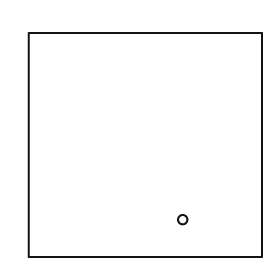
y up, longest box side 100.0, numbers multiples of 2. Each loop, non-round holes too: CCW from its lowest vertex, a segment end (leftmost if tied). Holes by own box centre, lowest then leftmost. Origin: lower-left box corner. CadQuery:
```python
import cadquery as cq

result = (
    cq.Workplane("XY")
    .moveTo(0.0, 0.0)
    .lineTo(100.0, 0.0)
    .lineTo(100.0, 96.0)
    .lineTo(0.0, 96.0)
    .close()
    .moveTo(66.0, 16.0)
    .circle(2.0)
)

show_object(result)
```